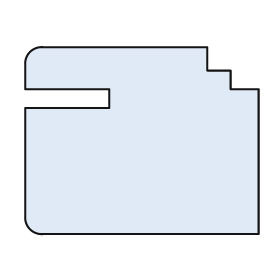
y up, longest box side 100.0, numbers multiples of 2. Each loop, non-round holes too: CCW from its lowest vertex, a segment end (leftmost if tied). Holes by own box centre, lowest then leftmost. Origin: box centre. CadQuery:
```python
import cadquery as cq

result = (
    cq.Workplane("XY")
    .moveTo(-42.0, -40.0)
    .lineTo(50.0, -40.0)
    .lineTo(50.0, 22.0)
    .lineTo(38.0, 22.0)
    .lineTo(38.0, 30.0)
    .lineTo(28.0, 30.0)
    .lineTo(28.0, 40.0)
    .lineTo(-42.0, 40.0)
    .threePointArc((-48.0, 38.0), (-50.0, 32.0))
    .lineTo(-50.0, 22.0)
    .lineTo(-14.0, 22.0)
    .lineTo(-14.0, 14.0)
    .lineTo(-50.0, 14.0)
    .lineTo(-50.0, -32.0)
    .threePointArc((-48.0, -38.0), (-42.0, -40.0))
    .close()
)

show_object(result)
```